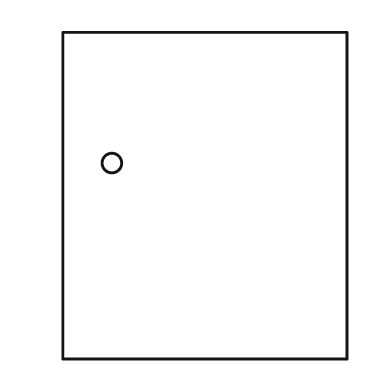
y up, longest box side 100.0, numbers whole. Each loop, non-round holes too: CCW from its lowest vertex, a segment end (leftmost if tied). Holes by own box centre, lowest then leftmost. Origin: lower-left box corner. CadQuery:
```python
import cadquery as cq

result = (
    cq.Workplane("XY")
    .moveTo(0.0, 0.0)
    .lineTo(87.0, 0.0)
    .lineTo(87.0, 100.0)
    .lineTo(0.0, 100.0)
    .close()
    .moveTo(15.0, 60.0)
    .circle(3.0)
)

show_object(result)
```